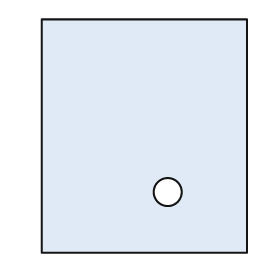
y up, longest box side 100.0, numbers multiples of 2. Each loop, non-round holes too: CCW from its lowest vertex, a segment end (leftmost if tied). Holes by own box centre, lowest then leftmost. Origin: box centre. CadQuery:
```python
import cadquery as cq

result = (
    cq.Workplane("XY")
    .moveTo(-44.0, -50.0)
    .lineTo(44.0, -50.0)
    .lineTo(44.0, 50.0)
    .lineTo(-44.0, 50.0)
    .close()
    .moveTo(10.0, -24.0)
    .circle(6.0)
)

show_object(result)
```